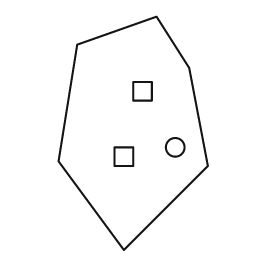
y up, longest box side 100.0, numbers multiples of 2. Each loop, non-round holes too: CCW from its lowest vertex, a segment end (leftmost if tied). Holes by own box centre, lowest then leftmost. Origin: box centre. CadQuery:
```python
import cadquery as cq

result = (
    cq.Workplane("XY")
    .moveTo(-4.0, -50.0)
    .lineTo(32.0, -14.0)
    .lineTo(24.0, 28.0)
    .lineTo(10.0, 50.0)
    .lineTo(-24.0, 38.0)
    .lineTo(-32.0, -12.0)
    .close()
    .moveTo(-8.0, -14.0)
    .lineTo(0.0, -14.0)
    .lineTo(0.0, -6.0)
    .lineTo(-8.0, -6.0)
    .close()
    .moveTo(18.0, -6.0)
    .circle(4.0)
    .moveTo(0.0, 14.0)
    .lineTo(8.0, 14.0)
    .lineTo(8.0, 22.0)
    .lineTo(0.0, 22.0)
    .close()
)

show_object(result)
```